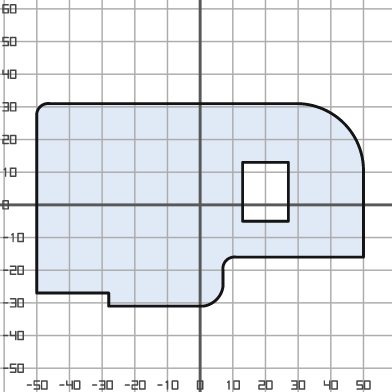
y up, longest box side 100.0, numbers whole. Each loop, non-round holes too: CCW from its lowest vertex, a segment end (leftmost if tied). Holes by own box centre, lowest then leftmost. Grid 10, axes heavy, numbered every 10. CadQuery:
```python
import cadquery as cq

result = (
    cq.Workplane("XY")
    .moveTo(-28.0, -31.0)
    .lineTo(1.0, -31.0)
    .threePointArc((5.0, -29.0), (7.0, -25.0))
    .lineTo(7.0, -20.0)
    .threePointArc((8.0, -17.0), (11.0, -16.0))
    .lineTo(50.0, -16.0)
    .lineTo(50.0, 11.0)
    .threePointArc((44.0, 25.0), (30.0, 31.0))
    .lineTo(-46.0, 31.0)
    .threePointArc((-49.0, 30.0), (-50.0, 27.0))
    .lineTo(-50.0, -27.0)
    .lineTo(-28.0, -27.0)
    .close()
    .moveTo(13.0, -5.0)
    .lineTo(27.0, -5.0)
    .lineTo(27.0, 13.0)
    .lineTo(13.0, 13.0)
    .close()
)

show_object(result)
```